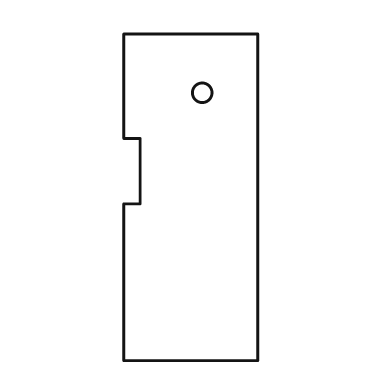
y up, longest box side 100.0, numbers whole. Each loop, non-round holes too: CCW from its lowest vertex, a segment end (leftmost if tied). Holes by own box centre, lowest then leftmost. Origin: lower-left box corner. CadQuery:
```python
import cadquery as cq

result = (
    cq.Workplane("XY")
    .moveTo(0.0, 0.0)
    .lineTo(41.0, 0.0)
    .lineTo(41.0, 100.0)
    .lineTo(0.0, 100.0)
    .lineTo(0.0, 68.0)
    .lineTo(5.0, 68.0)
    .lineTo(5.0, 48.0)
    .lineTo(0.0, 48.0)
    .close()
    .moveTo(24.0, 82.0)
    .circle(3.0)
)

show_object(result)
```